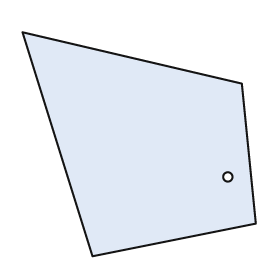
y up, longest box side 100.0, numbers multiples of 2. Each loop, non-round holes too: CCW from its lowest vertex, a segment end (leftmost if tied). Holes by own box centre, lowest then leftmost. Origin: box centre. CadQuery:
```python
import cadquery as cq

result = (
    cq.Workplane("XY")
    .moveTo(-20.0, -48.0)
    .lineTo(50.0, -34.0)
    .lineTo(44.0, 26.0)
    .lineTo(-50.0, 48.0)
    .close()
    .moveTo(38.0, -14.0)
    .circle(2.0)
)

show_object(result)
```